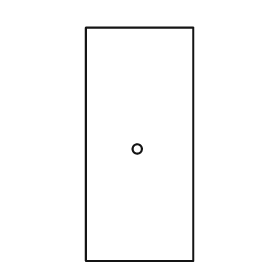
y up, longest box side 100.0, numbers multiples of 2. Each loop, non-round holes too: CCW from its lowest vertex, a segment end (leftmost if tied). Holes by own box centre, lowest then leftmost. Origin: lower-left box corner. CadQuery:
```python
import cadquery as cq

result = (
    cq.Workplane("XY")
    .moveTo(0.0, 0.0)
    .lineTo(46.0, 0.0)
    .lineTo(46.0, 100.0)
    .lineTo(0.0, 100.0)
    .close()
    .moveTo(22.0, 48.0)
    .circle(2.0)
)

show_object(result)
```